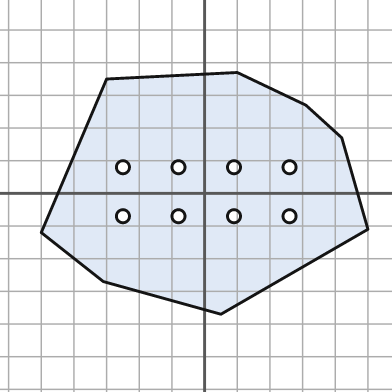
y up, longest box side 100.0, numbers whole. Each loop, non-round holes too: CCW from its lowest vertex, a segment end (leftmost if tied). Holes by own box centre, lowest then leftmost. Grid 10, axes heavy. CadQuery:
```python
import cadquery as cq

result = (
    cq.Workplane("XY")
    .moveTo(5.0, -37.0)
    .lineTo(50.0, -11.0)
    .lineTo(42.0, 17.0)
    .lineTo(31.0, 27.0)
    .lineTo(10.0, 37.0)
    .lineTo(-30.0, 35.0)
    .lineTo(-50.0, -12.0)
    .lineTo(-31.0, -27.0)
    .close()
    .moveTo(-25.0, -7.0)
    .circle(2.0)
    .moveTo(-8.0, -7.0)
    .circle(2.0)
    .moveTo(9.0, -7.0)
    .circle(2.0)
    .moveTo(26.0, -7.0)
    .circle(2.0)
    .moveTo(-25.0, 8.0)
    .circle(2.0)
    .moveTo(-8.0, 8.0)
    .circle(2.0)
    .moveTo(9.0, 8.0)
    .circle(2.0)
    .moveTo(26.0, 8.0)
    .circle(2.0)
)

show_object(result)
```